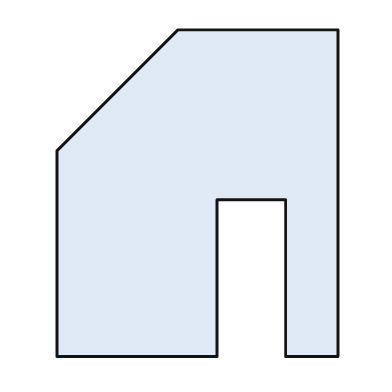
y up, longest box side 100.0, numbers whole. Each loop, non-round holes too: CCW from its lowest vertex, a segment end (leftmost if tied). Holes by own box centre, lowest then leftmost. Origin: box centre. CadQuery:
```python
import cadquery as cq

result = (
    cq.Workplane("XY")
    .moveTo(-43.0, -50.0)
    .lineTo(6.0, -50.0)
    .lineTo(6.0, -2.0)
    .lineTo(27.0, -2.0)
    .lineTo(27.0, -50.0)
    .lineTo(43.0, -50.0)
    .lineTo(43.0, 50.0)
    .lineTo(-6.0, 50.0)
    .lineTo(-43.0, 13.0)
    .close()
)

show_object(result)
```